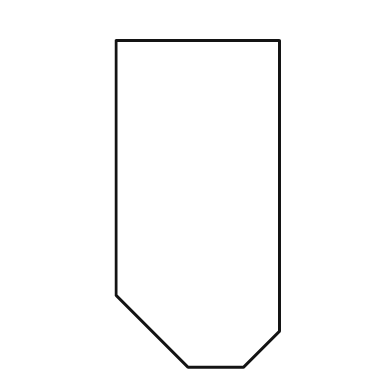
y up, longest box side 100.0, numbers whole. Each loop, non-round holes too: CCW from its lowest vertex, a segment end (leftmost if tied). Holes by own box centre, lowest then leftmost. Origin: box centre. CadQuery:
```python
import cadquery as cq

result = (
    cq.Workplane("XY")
    .moveTo(-3.0, -50.0)
    .lineTo(14.0, -50.0)
    .lineTo(25.0, -39.0)
    .lineTo(25.0, 50.0)
    .lineTo(-25.0, 50.0)
    .lineTo(-25.0, -28.0)
    .close()
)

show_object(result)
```